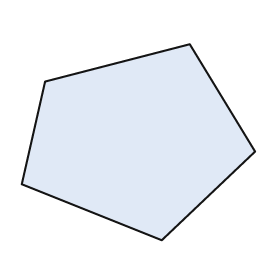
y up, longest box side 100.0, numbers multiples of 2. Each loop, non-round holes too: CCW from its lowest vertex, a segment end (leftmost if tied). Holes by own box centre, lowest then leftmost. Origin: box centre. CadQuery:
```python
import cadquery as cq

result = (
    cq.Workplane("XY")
    .moveTo(10.0, -42.0)
    .lineTo(50.0, -4.0)
    .lineTo(22.0, 42.0)
    .lineTo(-40.0, 26.0)
    .lineTo(-50.0, -18.0)
    .close()
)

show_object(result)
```